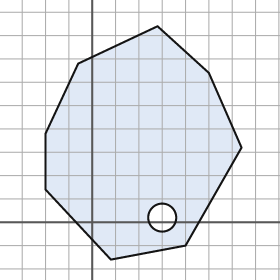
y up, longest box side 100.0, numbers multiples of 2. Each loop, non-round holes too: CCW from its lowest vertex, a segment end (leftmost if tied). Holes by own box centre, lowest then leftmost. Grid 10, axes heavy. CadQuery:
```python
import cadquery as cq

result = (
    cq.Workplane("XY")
    .moveTo(8.0, -16.0)
    .lineTo(40.0, -10.0)
    .lineTo(64.0, 32.0)
    .lineTo(50.0, 64.0)
    .lineTo(28.0, 84.0)
    .lineTo(-6.0, 68.0)
    .lineTo(-20.0, 38.0)
    .lineTo(-20.0, 14.0)
    .close()
    .moveTo(30.0, 2.0)
    .circle(6.0)
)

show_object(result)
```